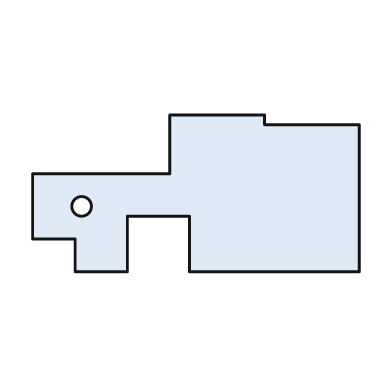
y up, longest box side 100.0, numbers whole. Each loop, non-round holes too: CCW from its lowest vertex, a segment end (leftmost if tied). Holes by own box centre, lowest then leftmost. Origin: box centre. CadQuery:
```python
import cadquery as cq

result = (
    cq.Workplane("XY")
    .moveTo(-37.0, -24.0)
    .lineTo(-21.0, -24.0)
    .lineTo(-21.0, -7.0)
    .lineTo(-2.0, -7.0)
    .lineTo(-2.0, -24.0)
    .lineTo(50.0, -24.0)
    .lineTo(50.0, 21.0)
    .lineTo(21.0, 21.0)
    .lineTo(21.0, 24.0)
    .lineTo(-8.0, 24.0)
    .lineTo(-8.0, 6.0)
    .lineTo(-50.0, 6.0)
    .lineTo(-50.0, -14.0)
    .lineTo(-37.0, -14.0)
    .close()
    .moveTo(-35.0, -4.0)
    .circle(3.0)
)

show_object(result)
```